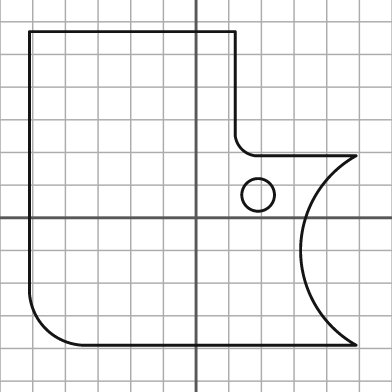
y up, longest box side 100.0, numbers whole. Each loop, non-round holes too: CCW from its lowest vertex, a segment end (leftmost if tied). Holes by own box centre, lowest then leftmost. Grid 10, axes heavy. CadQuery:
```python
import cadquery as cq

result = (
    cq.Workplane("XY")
    .moveTo(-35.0, -39.0)
    .lineTo(49.0, -39.0)
    .threePointArc((32.0, -10.0), (49.0, 19.0))
    .lineTo(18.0, 19.0)
    .threePointArc((14.0, 21.0), (12.0, 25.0))
    .lineTo(12.0, 57.0)
    .lineTo(-51.0, 57.0)
    .lineTo(-51.0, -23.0)
    .threePointArc((-46.0, -34.0), (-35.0, -39.0))
    .close()
    .moveTo(19.0, 7.0)
    .circle(5.0)
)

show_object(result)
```